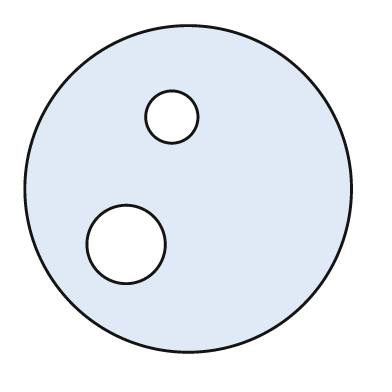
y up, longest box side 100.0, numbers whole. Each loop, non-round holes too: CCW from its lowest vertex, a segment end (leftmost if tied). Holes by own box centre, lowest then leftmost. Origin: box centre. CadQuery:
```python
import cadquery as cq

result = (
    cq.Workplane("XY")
    .moveTo(0.0, 0.0)
    .circle(50.0)
    .moveTo(-19.0, -17.0)
    .circle(12.0)
    .moveTo(-5.0, 22.0)
    .circle(8.0)
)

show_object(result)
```